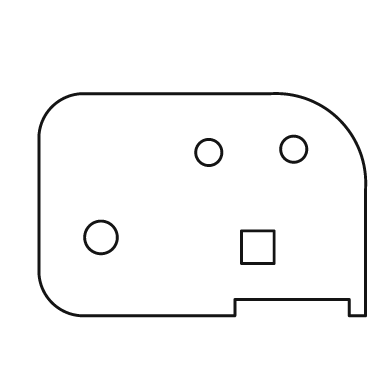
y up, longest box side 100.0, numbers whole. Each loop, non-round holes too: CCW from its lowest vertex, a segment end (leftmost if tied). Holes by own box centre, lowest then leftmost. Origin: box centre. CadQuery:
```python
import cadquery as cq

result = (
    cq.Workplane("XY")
    .moveTo(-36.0, -34.0)
    .lineTo(10.0, -34.0)
    .lineTo(10.0, -29.0)
    .lineTo(45.0, -29.0)
    .lineTo(45.0, -34.0)
    .lineTo(50.0, -34.0)
    .lineTo(50.0, 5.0)
    .threePointArc((42.0, 26.0), (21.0, 34.0))
    .lineTo(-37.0, 34.0)
    .threePointArc((-46.0, 30.0), (-50.0, 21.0))
    .lineTo(-50.0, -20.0)
    .threePointArc((-46.0, -30.0), (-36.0, -34.0))
    .close()
    .moveTo(12.0, -18.0)
    .lineTo(22.0, -18.0)
    .lineTo(22.0, -8.0)
    .lineTo(12.0, -8.0)
    .close()
    .moveTo(-31.0, -10.0)
    .circle(5.0)
    .moveTo(2.0, 16.0)
    .circle(4.0)
    .moveTo(28.0, 17.0)
    .circle(4.0)
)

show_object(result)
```